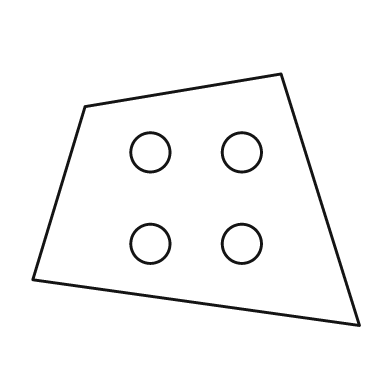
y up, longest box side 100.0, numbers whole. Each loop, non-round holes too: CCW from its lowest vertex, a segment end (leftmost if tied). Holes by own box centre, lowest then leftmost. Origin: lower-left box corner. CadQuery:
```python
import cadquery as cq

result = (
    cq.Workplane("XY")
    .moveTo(100.0, 0.0)
    .lineTo(76.0, 77.0)
    .lineTo(16.0, 67.0)
    .lineTo(0.0, 14.0)
    .close()
    .moveTo(36.0, 25.0)
    .circle(6.0)
    .moveTo(64.0, 25.0)
    .circle(6.0)
    .moveTo(36.0, 53.0)
    .circle(6.0)
    .moveTo(64.0, 53.0)
    .circle(6.0)
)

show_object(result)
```